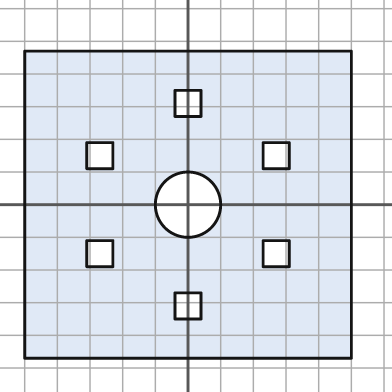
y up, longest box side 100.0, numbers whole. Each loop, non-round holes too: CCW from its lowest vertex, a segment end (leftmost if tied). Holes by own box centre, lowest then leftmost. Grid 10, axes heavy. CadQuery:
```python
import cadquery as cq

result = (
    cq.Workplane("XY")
    .moveTo(-50.0, -47.0)
    .lineTo(50.0, -47.0)
    .lineTo(50.0, 47.0)
    .lineTo(-50.0, 47.0)
    .close()
    .moveTo(-4.0, -35.0)
    .lineTo(4.0, -35.0)
    .lineTo(4.0, -27.0)
    .lineTo(-4.0, -27.0)
    .close()
    .moveTo(-31.0, -19.0)
    .lineTo(-23.0, -19.0)
    .lineTo(-23.0, -11.0)
    .lineTo(-31.0, -11.0)
    .close()
    .moveTo(23.0, -19.0)
    .lineTo(31.0, -19.0)
    .lineTo(31.0, -11.0)
    .lineTo(23.0, -11.0)
    .close()
    .moveTo(0.0, 0.0)
    .circle(10.0)
    .moveTo(-31.0, 11.0)
    .lineTo(-23.0, 11.0)
    .lineTo(-23.0, 19.0)
    .lineTo(-31.0, 19.0)
    .close()
    .moveTo(23.0, 11.0)
    .lineTo(31.0, 11.0)
    .lineTo(31.0, 19.0)
    .lineTo(23.0, 19.0)
    .close()
    .moveTo(-4.0, 27.0)
    .lineTo(4.0, 27.0)
    .lineTo(4.0, 35.0)
    .lineTo(-4.0, 35.0)
    .close()
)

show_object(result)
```